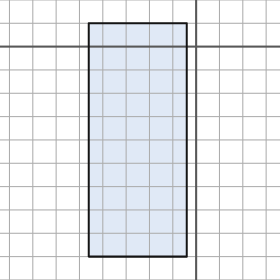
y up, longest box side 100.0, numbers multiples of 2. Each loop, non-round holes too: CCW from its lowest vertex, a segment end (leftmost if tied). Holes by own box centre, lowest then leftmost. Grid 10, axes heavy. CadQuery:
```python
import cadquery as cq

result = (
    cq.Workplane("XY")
    .moveTo(-46.0, -90.0)
    .lineTo(-4.0, -90.0)
    .lineTo(-4.0, 10.0)
    .lineTo(-46.0, 10.0)
    .close()
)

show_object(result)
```